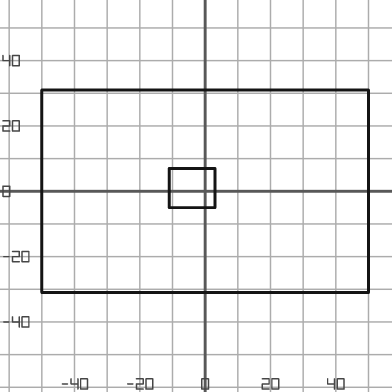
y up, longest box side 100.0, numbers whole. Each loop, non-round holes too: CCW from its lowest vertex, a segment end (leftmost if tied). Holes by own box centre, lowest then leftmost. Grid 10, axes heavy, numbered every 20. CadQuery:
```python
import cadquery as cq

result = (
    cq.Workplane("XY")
    .moveTo(-50.0, -31.0)
    .lineTo(50.0, -31.0)
    .lineTo(50.0, 31.0)
    .lineTo(-50.0, 31.0)
    .close()
    .moveTo(-11.0, -5.0)
    .lineTo(3.0, -5.0)
    .lineTo(3.0, 7.0)
    .lineTo(-11.0, 7.0)
    .close()
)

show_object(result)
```